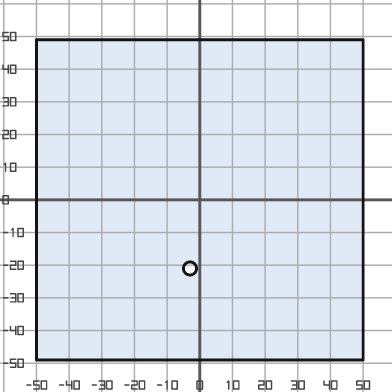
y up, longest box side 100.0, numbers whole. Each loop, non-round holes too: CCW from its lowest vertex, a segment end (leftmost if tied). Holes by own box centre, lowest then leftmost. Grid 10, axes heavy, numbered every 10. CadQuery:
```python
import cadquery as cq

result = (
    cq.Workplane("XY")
    .moveTo(-50.0, -49.0)
    .lineTo(50.0, -49.0)
    .lineTo(50.0, 49.0)
    .lineTo(-50.0, 49.0)
    .close()
    .moveTo(-3.0, -21.0)
    .circle(2.0)
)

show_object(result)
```